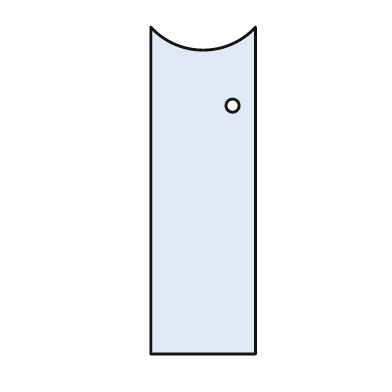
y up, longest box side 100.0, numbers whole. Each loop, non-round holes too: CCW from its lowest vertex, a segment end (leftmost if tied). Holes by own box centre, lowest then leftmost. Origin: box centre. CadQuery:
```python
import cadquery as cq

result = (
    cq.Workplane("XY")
    .moveTo(-16.0, -50.0)
    .lineTo(16.0, -50.0)
    .lineTo(16.0, 50.0)
    .threePointArc((0.0, 43.0), (-16.0, 50.0))
    .close()
    .moveTo(9.0, 26.0)
    .circle(2.0)
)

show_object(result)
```